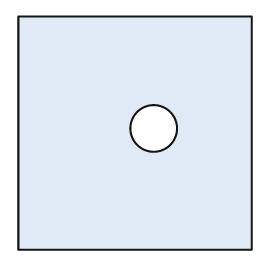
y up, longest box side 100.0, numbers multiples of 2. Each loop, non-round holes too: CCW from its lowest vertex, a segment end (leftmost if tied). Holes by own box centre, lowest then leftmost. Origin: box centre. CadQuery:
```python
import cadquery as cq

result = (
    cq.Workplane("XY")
    .moveTo(-50.0, -50.0)
    .lineTo(50.0, -50.0)
    .lineTo(50.0, 50.0)
    .lineTo(-50.0, 50.0)
    .close()
    .moveTo(8.0, 2.0)
    .circle(10.0)
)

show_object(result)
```